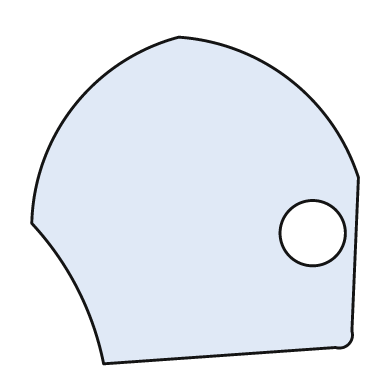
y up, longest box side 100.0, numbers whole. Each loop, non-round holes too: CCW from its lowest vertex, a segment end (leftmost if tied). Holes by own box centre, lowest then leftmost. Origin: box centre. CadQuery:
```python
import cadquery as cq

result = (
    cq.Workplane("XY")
    .moveTo(-28.0, -50.0)
    .lineTo(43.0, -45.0)
    .threePointArc((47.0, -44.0), (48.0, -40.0))
    .lineTo(50.0, 7.0)
    .threePointArc((29.0, 37.0), (-5.0, 50.0))
    .threePointArc((-37.0, 29.0), (-50.0, -7.0))
    .threePointArc((-36.0, -27.0), (-28.0, -50.0))
    .close()
    .moveTo(36.0, -10.0)
    .circle(10.0)
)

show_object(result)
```